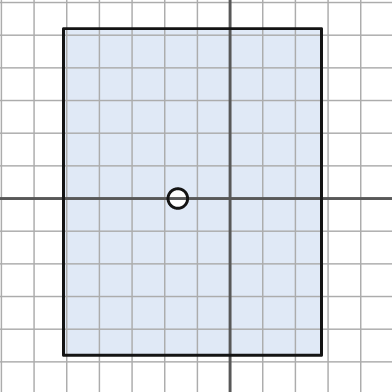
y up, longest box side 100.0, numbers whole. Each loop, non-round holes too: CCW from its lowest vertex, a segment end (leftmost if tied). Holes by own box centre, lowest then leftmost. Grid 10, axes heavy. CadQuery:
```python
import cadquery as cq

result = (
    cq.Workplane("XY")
    .moveTo(-51.0, -48.0)
    .lineTo(28.0, -48.0)
    .lineTo(28.0, 52.0)
    .lineTo(-51.0, 52.0)
    .close()
    .moveTo(-16.0, 0.0)
    .circle(3.0)
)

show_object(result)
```